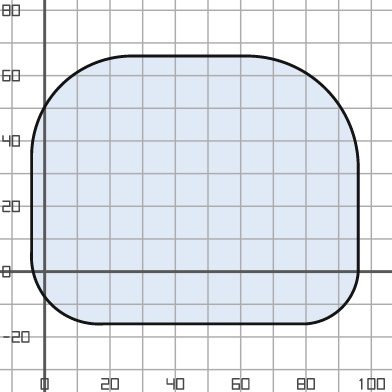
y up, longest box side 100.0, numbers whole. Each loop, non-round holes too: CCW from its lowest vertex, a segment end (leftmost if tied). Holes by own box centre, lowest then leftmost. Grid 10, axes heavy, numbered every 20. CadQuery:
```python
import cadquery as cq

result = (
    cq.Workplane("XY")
    .moveTo(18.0, -16.0)
    .lineTo(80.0, -16.0)
    .threePointArc((91.0, -11.0), (96.0, 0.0))
    .lineTo(96.0, 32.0)
    .threePointArc((86.0, 56.0), (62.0, 66.0))
    .lineTo(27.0, 66.0)
    .threePointArc((5.0, 57.0), (-4.0, 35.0))
    .lineTo(-4.0, 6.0)
    .threePointArc((2.0, -10.0), (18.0, -16.0))
    .close()
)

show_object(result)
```